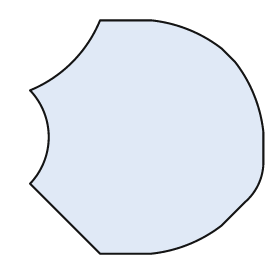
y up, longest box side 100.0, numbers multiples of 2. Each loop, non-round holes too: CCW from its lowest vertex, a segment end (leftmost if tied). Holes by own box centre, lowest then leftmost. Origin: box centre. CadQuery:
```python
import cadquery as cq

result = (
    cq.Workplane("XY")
    .moveTo(-20.0, -50.0)
    .lineTo(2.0, -50.0)
    .threePointArc((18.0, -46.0), (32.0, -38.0))
    .lineTo(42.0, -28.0)
    .threePointArc((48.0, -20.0), (50.0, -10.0))
    .lineTo(50.0, 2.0)
    .threePointArc((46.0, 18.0), (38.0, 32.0))
    .lineTo(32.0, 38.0)
    .threePointArc((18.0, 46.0), (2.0, 50.0))
    .lineTo(-20.0, 50.0)
    .threePointArc((-32.0, 32.0), (-50.0, 20.0))
    .threePointArc((-42.0, 0.0), (-50.0, -20.0))
    .close()
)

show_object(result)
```